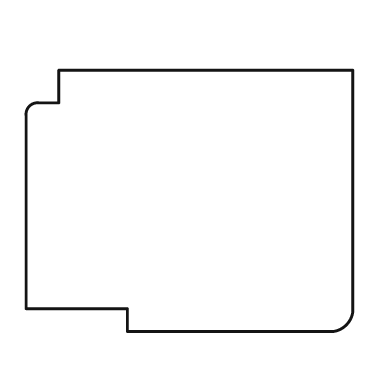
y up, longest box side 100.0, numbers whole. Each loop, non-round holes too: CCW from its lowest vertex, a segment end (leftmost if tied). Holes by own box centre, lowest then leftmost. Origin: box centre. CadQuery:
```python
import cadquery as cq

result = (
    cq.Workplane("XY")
    .moveTo(-19.0, -40.0)
    .lineTo(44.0, -40.0)
    .threePointArc((48.0, -38.0), (50.0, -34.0))
    .lineTo(50.0, 40.0)
    .lineTo(-40.0, 40.0)
    .lineTo(-40.0, 30.0)
    .lineTo(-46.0, 30.0)
    .threePointArc((-49.0, 29.0), (-50.0, 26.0))
    .lineTo(-50.0, -33.0)
    .lineTo(-19.0, -33.0)
    .close()
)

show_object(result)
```